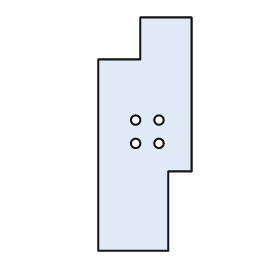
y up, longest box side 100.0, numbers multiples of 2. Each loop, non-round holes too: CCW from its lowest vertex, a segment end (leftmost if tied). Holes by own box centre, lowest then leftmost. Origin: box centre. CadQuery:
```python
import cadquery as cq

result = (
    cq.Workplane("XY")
    .moveTo(-20.0, -50.0)
    .lineTo(10.0, -50.0)
    .lineTo(10.0, -16.0)
    .lineTo(20.0, -16.0)
    .lineTo(20.0, 50.0)
    .lineTo(-2.0, 50.0)
    .lineTo(-2.0, 32.0)
    .lineTo(-20.0, 32.0)
    .close()
    .moveTo(-4.0, -4.0)
    .circle(2.0)
    .moveTo(6.0, -4.0)
    .circle(2.0)
    .moveTo(-4.0, 6.0)
    .circle(2.0)
    .moveTo(6.0, 6.0)
    .circle(2.0)
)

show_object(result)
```